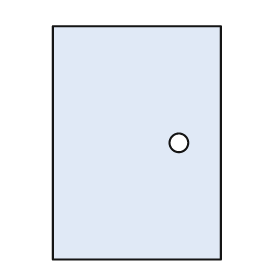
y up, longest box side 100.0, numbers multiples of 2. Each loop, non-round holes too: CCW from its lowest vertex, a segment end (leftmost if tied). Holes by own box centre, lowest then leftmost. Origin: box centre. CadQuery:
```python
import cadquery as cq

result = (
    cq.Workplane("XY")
    .moveTo(-36.0, -50.0)
    .lineTo(36.0, -50.0)
    .lineTo(36.0, 50.0)
    .lineTo(-36.0, 50.0)
    .close()
    .moveTo(18.0, 0.0)
    .circle(4.0)
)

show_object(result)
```